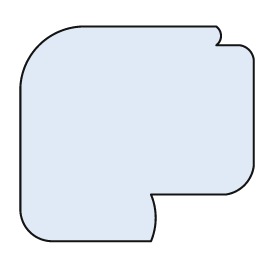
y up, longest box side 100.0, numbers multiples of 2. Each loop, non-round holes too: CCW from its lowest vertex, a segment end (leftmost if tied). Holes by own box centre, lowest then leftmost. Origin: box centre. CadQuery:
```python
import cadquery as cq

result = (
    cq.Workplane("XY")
    .moveTo(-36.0, -46.0)
    .lineTo(6.0, -46.0)
    .threePointArc((8.0, -36.0), (6.0, -26.0))
    .lineTo(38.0, -26.0)
    .threePointArc((46.0, -22.0), (50.0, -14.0))
    .lineTo(50.0, 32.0)
    .threePointArc((48.0, 36.0), (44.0, 38.0))
    .lineTo(34.0, 38.0)
    .threePointArc((36.0, 42.0), (34.0, 46.0))
    .lineTo(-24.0, 46.0)
    .threePointArc((-42.0, 38.0), (-50.0, 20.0))
    .lineTo(-50.0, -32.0)
    .threePointArc((-46.0, -42.0), (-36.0, -46.0))
    .close()
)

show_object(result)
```